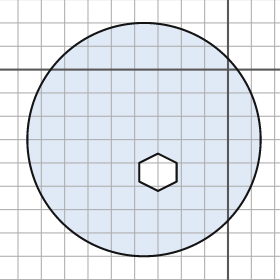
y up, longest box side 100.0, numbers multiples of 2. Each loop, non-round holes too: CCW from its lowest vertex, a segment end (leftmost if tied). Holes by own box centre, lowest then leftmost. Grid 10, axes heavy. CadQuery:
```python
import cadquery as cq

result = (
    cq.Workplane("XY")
    .moveTo(-36.0, -30.0)
    .circle(50.0)
    .moveTo(-30.0, -52.0)
    .lineTo(-22.0, -48.0)
    .lineTo(-22.0, -40.0)
    .lineTo(-30.0, -36.0)
    .lineTo(-38.0, -40.0)
    .lineTo(-38.0, -48.0)
    .close()
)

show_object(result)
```